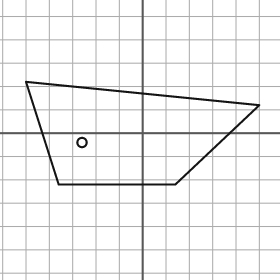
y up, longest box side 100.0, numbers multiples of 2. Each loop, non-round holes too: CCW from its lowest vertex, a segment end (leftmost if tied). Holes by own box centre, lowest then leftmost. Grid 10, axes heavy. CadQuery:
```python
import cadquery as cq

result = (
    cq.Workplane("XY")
    .moveTo(-36.0, -22.0)
    .lineTo(14.0, -22.0)
    .lineTo(50.0, 12.0)
    .lineTo(-50.0, 22.0)
    .close()
    .moveTo(-26.0, -4.0)
    .circle(2.0)
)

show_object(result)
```